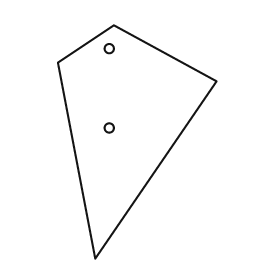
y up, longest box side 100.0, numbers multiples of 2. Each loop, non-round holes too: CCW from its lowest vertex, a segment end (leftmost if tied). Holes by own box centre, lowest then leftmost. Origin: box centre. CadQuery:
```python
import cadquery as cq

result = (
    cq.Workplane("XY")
    .moveTo(-18.0, -50.0)
    .lineTo(34.0, 26.0)
    .lineTo(-10.0, 50.0)
    .lineTo(-34.0, 34.0)
    .close()
    .moveTo(-12.0, 6.0)
    .circle(2.0)
    .moveTo(-12.0, 40.0)
    .circle(2.0)
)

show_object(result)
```